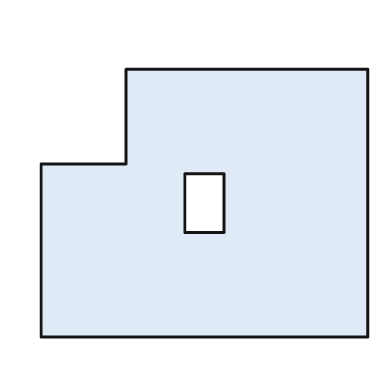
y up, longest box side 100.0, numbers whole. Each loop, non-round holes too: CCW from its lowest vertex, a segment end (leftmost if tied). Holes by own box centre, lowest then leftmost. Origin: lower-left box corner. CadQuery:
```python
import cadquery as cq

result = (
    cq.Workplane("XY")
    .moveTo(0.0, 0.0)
    .lineTo(100.0, 0.0)
    .lineTo(100.0, 82.0)
    .lineTo(26.0, 82.0)
    .lineTo(26.0, 53.0)
    .lineTo(0.0, 53.0)
    .close()
    .moveTo(44.0, 32.0)
    .lineTo(56.0, 32.0)
    .lineTo(56.0, 50.0)
    .lineTo(44.0, 50.0)
    .close()
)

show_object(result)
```